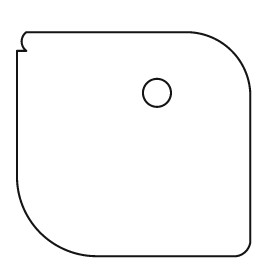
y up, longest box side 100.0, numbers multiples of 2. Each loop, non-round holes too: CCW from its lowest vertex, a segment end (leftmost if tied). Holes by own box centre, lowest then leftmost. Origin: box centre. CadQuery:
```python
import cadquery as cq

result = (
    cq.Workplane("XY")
    .moveTo(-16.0, -48.0)
    .lineTo(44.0, -48.0)
    .threePointArc((48.0, -46.0), (50.0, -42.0))
    .lineTo(50.0, 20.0)
    .threePointArc((42.0, 40.0), (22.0, 48.0))
    .lineTo(-46.0, 48.0)
    .threePointArc((-48.0, 44.0), (-46.0, 40.0))
    .lineTo(-50.0, 40.0)
    .lineTo(-50.0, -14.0)
    .threePointArc((-40.0, -38.0), (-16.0, -48.0))
    .close()
    .moveTo(10.0, 22.0)
    .circle(6.0)
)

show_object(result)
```